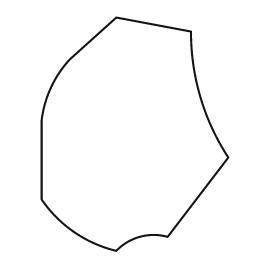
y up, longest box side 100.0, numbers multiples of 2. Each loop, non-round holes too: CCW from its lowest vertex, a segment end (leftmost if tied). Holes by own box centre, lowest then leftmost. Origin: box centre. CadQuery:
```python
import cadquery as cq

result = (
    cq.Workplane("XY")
    .moveTo(-8.0, -50.0)
    .threePointArc((2.0, -44.0), (14.0, -44.0))
    .lineTo(40.0, -10.0)
    .threePointArc((28.0, 16.0), (24.0, 44.0))
    .lineTo(-8.0, 50.0)
    .lineTo(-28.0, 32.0)
    .threePointArc((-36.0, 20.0), (-40.0, 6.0))
    .lineTo(-40.0, -28.0)
    .threePointArc((-26.0, -42.0), (-8.0, -50.0))
    .close()
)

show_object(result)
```